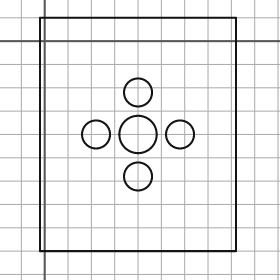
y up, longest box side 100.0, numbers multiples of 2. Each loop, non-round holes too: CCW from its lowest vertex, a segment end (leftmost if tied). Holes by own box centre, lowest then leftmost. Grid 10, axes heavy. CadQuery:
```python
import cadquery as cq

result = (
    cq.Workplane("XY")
    .moveTo(-2.0, -90.0)
    .lineTo(82.0, -90.0)
    .lineTo(82.0, 10.0)
    .lineTo(-2.0, 10.0)
    .close()
    .moveTo(40.0, -58.0)
    .circle(6.0)
    .moveTo(22.0, -40.0)
    .circle(6.0)
    .moveTo(40.0, -40.0)
    .circle(8.0)
    .moveTo(58.0, -40.0)
    .circle(6.0)
    .moveTo(40.0, -22.0)
    .circle(6.0)
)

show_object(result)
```